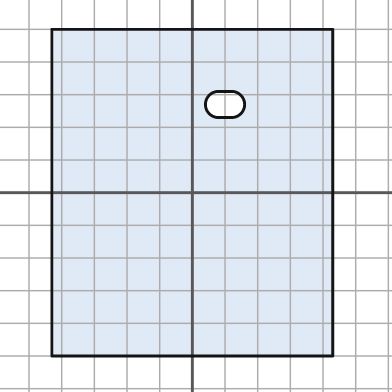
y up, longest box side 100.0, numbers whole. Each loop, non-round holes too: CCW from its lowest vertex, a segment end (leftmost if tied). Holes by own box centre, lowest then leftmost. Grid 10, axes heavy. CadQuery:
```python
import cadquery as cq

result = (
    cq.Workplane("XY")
    .moveTo(-43.0, -50.0)
    .lineTo(43.0, -50.0)
    .lineTo(43.0, 50.0)
    .lineTo(-43.0, 50.0)
    .close()
    .moveTo(8.0, 23.0)
    .lineTo(12.0, 23.0)
    .threePointArc((16.0, 27.0), (12.0, 31.0))
    .lineTo(8.0, 31.0)
    .threePointArc((4.0, 27.0), (8.0, 23.0))
    .close()
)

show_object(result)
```